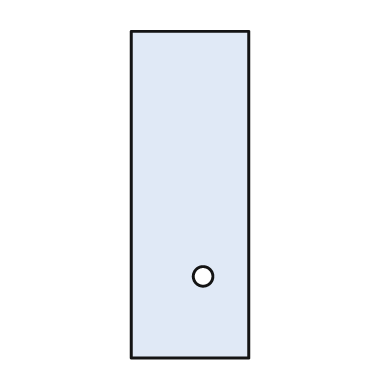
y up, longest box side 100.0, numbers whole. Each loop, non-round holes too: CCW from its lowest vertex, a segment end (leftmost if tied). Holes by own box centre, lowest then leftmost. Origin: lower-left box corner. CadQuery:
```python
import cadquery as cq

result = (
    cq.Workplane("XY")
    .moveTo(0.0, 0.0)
    .lineTo(36.0, 0.0)
    .lineTo(36.0, 100.0)
    .lineTo(0.0, 100.0)
    .close()
    .moveTo(22.0, 25.0)
    .circle(3.0)
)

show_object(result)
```